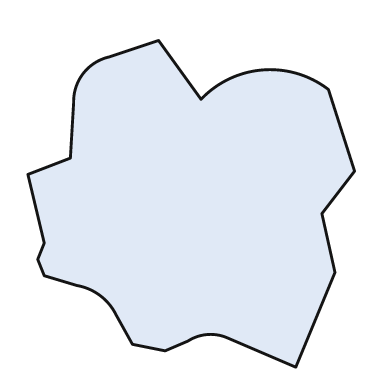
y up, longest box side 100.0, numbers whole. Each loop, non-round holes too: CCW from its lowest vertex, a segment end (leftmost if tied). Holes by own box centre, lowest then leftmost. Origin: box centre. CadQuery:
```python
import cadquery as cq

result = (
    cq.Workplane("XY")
    .moveTo(32.0, -50.0)
    .lineTo(44.0, -21.0)
    .lineTo(40.0, -3.0)
    .lineTo(50.0, 10.0)
    .lineTo(42.0, 35.0)
    .threePointArc((22.0, 41.0), (3.0, 32.0))
    .lineTo(-10.0, 50.0)
    .lineTo(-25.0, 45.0)
    .threePointArc((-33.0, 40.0), (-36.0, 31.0))
    .lineTo(-37.0, 14.0)
    .lineTo(-50.0, 9.0)
    .lineTo(-45.0, -12.0)
    .lineTo(-47.0, -17.0)
    .lineTo(-45.0, -22.0)
    .lineTo(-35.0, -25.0)
    .threePointArc((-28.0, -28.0), (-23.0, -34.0))
    .lineTo(-18.0, -43.0)
    .lineTo(-8.0, -45.0)
    .lineTo(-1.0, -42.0)
    .threePointArc((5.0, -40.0), (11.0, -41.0))
    .close()
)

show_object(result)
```